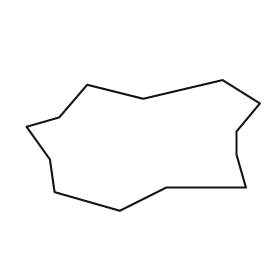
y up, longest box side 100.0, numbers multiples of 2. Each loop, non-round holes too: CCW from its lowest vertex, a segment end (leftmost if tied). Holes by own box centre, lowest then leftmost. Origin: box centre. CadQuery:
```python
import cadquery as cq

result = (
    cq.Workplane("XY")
    .moveTo(-10.0, -28.0)
    .lineTo(10.0, -18.0)
    .lineTo(44.0, -18.0)
    .lineTo(40.0, -4.0)
    .lineTo(40.0, 6.0)
    .lineTo(50.0, 18.0)
    .lineTo(34.0, 28.0)
    .lineTo(0.0, 20.0)
    .lineTo(-24.0, 26.0)
    .lineTo(-36.0, 12.0)
    .lineTo(-50.0, 8.0)
    .lineTo(-40.0, -6.0)
    .lineTo(-38.0, -20.0)
    .close()
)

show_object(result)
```